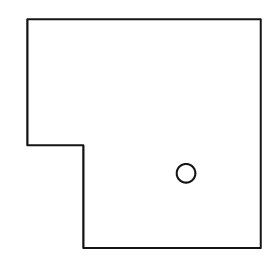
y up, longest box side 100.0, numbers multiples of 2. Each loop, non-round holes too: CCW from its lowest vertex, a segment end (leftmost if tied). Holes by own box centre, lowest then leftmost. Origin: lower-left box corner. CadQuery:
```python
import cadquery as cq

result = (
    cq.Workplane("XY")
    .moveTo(24.0, 0.0)
    .lineTo(100.0, 0.0)
    .lineTo(100.0, 98.0)
    .lineTo(0.0, 98.0)
    .lineTo(0.0, 44.0)
    .lineTo(24.0, 44.0)
    .close()
    .moveTo(68.0, 32.0)
    .circle(4.0)
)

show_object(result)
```